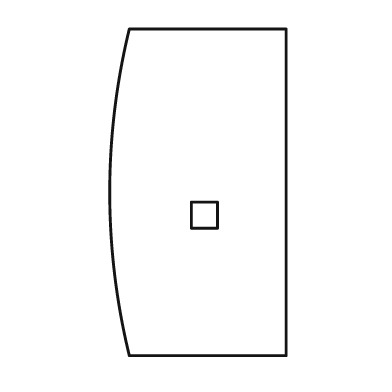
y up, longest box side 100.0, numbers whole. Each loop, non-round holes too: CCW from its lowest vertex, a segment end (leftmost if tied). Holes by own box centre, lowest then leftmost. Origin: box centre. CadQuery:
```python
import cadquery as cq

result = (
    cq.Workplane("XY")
    .moveTo(-21.0, -50.0)
    .lineTo(27.0, -50.0)
    .lineTo(27.0, 50.0)
    .lineTo(-21.0, 50.0)
    .threePointArc((-27.0, 0.0), (-21.0, -50.0))
    .close()
    .moveTo(-2.0, -11.0)
    .lineTo(6.0, -11.0)
    .lineTo(6.0, -3.0)
    .lineTo(-2.0, -3.0)
    .close()
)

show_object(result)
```